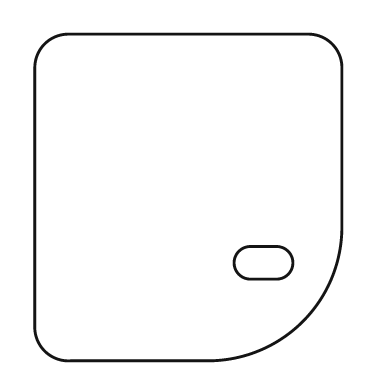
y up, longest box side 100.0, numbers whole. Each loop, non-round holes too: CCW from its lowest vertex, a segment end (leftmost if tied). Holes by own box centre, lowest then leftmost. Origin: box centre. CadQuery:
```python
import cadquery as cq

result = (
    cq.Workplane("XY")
    .moveTo(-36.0, -50.0)
    .lineTo(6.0, -50.0)
    .threePointArc((35.0, -38.0), (47.0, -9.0))
    .lineTo(47.0, 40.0)
    .threePointArc((44.0, 47.0), (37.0, 50.0))
    .lineTo(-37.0, 50.0)
    .threePointArc((-44.0, 47.0), (-47.0, 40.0))
    .lineTo(-47.0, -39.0)
    .threePointArc((-44.0, -47.0), (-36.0, -50.0))
    .close()
    .moveTo(19.0, -25.0)
    .lineTo(27.0, -25.0)
    .threePointArc((32.0, -20.0), (27.0, -15.0))
    .lineTo(19.0, -15.0)
    .threePointArc((14.0, -20.0), (19.0, -25.0))
    .close()
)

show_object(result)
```